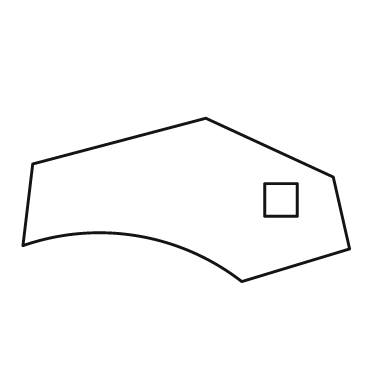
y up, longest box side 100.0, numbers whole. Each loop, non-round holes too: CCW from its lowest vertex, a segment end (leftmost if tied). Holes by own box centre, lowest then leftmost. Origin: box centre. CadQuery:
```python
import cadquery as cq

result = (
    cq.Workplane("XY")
    .moveTo(17.0, -25.0)
    .lineTo(50.0, -15.0)
    .lineTo(45.0, 7.0)
    .lineTo(6.0, 25.0)
    .lineTo(-47.0, 11.0)
    .lineTo(-50.0, -14.0)
    .threePointArc((-15.0, -11.0), (17.0, -25.0))
    .close()
    .moveTo(24.0, -5.0)
    .lineTo(34.0, -5.0)
    .lineTo(34.0, 5.0)
    .lineTo(24.0, 5.0)
    .close()
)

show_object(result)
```